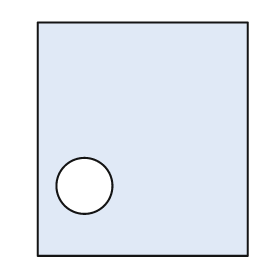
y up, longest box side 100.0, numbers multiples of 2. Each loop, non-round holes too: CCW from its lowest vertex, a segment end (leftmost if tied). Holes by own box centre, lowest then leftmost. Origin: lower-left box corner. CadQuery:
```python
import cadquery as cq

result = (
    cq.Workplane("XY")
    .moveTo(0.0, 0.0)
    .lineTo(90.0, 0.0)
    .lineTo(90.0, 100.0)
    .lineTo(0.0, 100.0)
    .close()
    .moveTo(20.0, 30.0)
    .circle(12.0)
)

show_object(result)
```